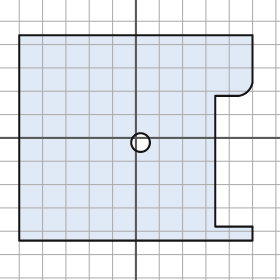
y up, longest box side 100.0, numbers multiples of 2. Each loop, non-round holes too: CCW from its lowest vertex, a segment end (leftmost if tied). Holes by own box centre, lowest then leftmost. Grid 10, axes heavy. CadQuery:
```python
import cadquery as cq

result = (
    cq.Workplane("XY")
    .moveTo(-50.0, -44.0)
    .lineTo(50.0, -44.0)
    .lineTo(50.0, -38.0)
    .lineTo(34.0, -38.0)
    .lineTo(34.0, 18.0)
    .lineTo(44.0, 18.0)
    .threePointArc((48.0, 20.0), (50.0, 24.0))
    .lineTo(50.0, 44.0)
    .lineTo(-50.0, 44.0)
    .close()
    .moveTo(2.0, -2.0)
    .circle(4.0)
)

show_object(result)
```